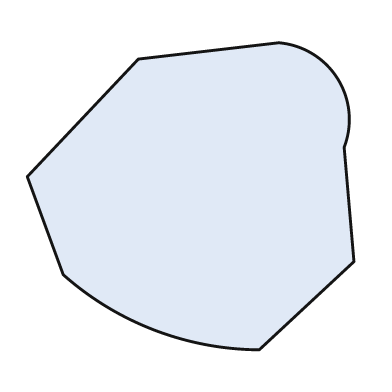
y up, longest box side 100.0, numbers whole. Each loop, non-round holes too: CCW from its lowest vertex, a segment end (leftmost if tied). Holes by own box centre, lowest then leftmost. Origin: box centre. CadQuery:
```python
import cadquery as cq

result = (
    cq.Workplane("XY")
    .moveTo(21.0, -47.0)
    .lineTo(50.0, -20.0)
    .lineTo(47.0, 15.0)
    .threePointArc((45.0, 36.0), (27.0, 47.0))
    .lineTo(-16.0, 42.0)
    .lineTo(-50.0, 6.0)
    .lineTo(-39.0, -24.0)
    .threePointArc((-11.0, -41.0), (21.0, -47.0))
    .close()
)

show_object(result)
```